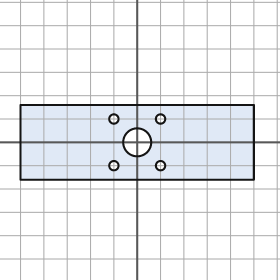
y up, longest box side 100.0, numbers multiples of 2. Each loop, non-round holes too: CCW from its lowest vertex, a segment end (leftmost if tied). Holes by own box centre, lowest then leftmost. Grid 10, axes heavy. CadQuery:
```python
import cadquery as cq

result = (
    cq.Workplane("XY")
    .moveTo(-50.0, -16.0)
    .lineTo(50.0, -16.0)
    .lineTo(50.0, 16.0)
    .lineTo(-50.0, 16.0)
    .close()
    .moveTo(-10.0, -10.0)
    .circle(2.0)
    .moveTo(10.0, -10.0)
    .circle(2.0)
    .moveTo(0.0, 0.0)
    .circle(6.0)
    .moveTo(-10.0, 10.0)
    .circle(2.0)
    .moveTo(10.0, 10.0)
    .circle(2.0)
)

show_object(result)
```